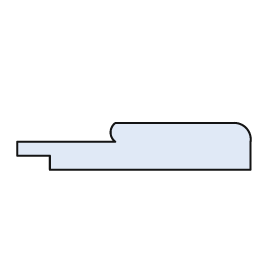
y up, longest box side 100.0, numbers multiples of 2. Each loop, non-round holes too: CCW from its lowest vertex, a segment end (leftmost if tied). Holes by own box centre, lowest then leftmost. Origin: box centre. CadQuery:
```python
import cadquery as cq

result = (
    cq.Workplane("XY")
    .moveTo(-36.0, -10.0)
    .lineTo(50.0, -10.0)
    .lineTo(50.0, 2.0)
    .threePointArc((48.0, 8.0), (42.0, 10.0))
    .lineTo(-8.0, 10.0)
    .threePointArc((-10.0, 6.0), (-8.0, 2.0))
    .lineTo(-50.0, 2.0)
    .lineTo(-50.0, -4.0)
    .lineTo(-36.0, -4.0)
    .close()
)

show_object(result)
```